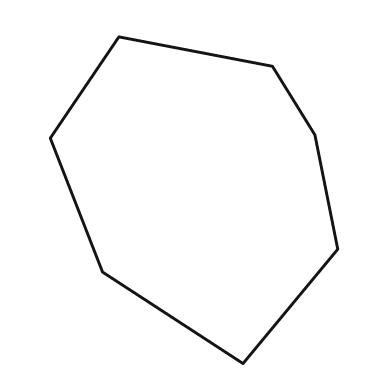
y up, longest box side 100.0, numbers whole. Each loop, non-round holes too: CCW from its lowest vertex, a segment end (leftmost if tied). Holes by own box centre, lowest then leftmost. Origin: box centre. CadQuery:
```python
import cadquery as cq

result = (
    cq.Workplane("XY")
    .moveTo(15.0, -50.0)
    .lineTo(44.0, -15.0)
    .lineTo(37.0, 20.0)
    .lineTo(24.0, 41.0)
    .lineTo(-23.0, 50.0)
    .lineTo(-44.0, 19.0)
    .lineTo(-28.0, -22.0)
    .close()
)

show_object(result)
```